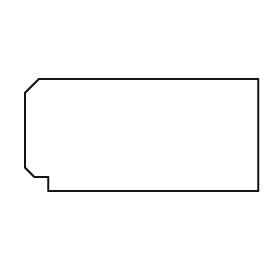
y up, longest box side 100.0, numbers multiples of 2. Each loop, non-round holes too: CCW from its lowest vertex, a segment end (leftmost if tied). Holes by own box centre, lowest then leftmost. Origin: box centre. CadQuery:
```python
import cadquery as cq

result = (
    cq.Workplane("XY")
    .moveTo(-40.0, -24.0)
    .lineTo(50.0, -24.0)
    .lineTo(50.0, 24.0)
    .lineTo(-44.0, 24.0)
    .lineTo(-50.0, 18.0)
    .lineTo(-50.0, -14.0)
    .lineTo(-46.0, -18.0)
    .lineTo(-40.0, -18.0)
    .close()
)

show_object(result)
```